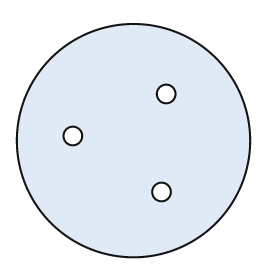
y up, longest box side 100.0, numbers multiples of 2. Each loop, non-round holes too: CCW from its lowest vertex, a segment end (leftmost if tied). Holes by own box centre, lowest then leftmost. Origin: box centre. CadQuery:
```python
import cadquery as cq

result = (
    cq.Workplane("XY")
    .moveTo(0.0, 0.0)
    .circle(50.0)
    .moveTo(12.0, -22.0)
    .circle(4.0)
    .moveTo(-26.0, 2.0)
    .circle(4.0)
    .moveTo(14.0, 20.0)
    .circle(4.0)
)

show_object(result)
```